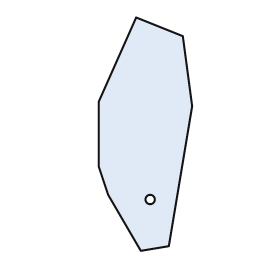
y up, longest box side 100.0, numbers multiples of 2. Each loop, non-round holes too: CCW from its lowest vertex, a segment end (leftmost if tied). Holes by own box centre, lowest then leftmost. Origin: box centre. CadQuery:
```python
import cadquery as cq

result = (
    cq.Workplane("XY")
    .moveTo(-2.0, -50.0)
    .lineTo(10.0, -48.0)
    .lineTo(20.0, 12.0)
    .lineTo(16.0, 42.0)
    .lineTo(-4.0, 50.0)
    .lineTo(-20.0, 14.0)
    .lineTo(-20.0, -14.0)
    .lineTo(-16.0, -26.0)
    .close()
    .moveTo(2.0, -28.0)
    .circle(2.0)
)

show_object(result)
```